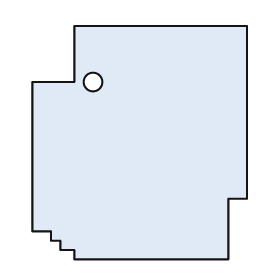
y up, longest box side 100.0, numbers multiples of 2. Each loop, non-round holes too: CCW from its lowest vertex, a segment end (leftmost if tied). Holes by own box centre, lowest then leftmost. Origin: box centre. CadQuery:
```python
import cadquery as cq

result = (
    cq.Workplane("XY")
    .moveTo(-28.0, -50.0)
    .lineTo(38.0, -50.0)
    .lineTo(38.0, -24.0)
    .lineTo(46.0, -24.0)
    .lineTo(46.0, 50.0)
    .lineTo(-28.0, 50.0)
    .lineTo(-28.0, 26.0)
    .lineTo(-46.0, 26.0)
    .lineTo(-46.0, -38.0)
    .lineTo(-38.0, -38.0)
    .lineTo(-38.0, -42.0)
    .lineTo(-34.0, -42.0)
    .lineTo(-34.0, -46.0)
    .lineTo(-28.0, -46.0)
    .close()
    .moveTo(-20.0, 26.0)
    .circle(4.0)
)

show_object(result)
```